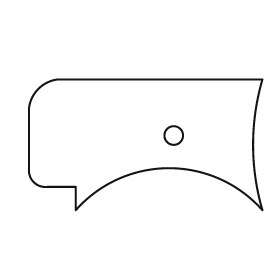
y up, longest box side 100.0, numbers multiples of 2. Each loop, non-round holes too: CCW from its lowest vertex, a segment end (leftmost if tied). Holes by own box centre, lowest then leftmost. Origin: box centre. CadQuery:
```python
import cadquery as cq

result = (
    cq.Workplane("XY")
    .moveTo(-30.0, -28.0)
    .threePointArc((10.0, -10.0), (50.0, -28.0))
    .threePointArc((46.0, 0.0), (50.0, 28.0))
    .lineTo(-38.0, 28.0)
    .threePointArc((-46.0, 24.0), (-50.0, 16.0))
    .lineTo(-50.0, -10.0)
    .threePointArc((-48.0, -16.0), (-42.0, -18.0))
    .lineTo(-30.0, -18.0)
    .close()
    .moveTo(12.0, 4.0)
    .circle(4.0)
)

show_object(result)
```